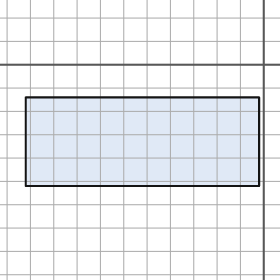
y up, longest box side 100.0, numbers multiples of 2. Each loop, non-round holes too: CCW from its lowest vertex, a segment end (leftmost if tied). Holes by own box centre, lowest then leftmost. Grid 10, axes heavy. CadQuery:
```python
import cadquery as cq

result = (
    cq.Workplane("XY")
    .moveTo(-102.0, -52.0)
    .lineTo(-2.0, -52.0)
    .lineTo(-2.0, -14.0)
    .lineTo(-102.0, -14.0)
    .close()
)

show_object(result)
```